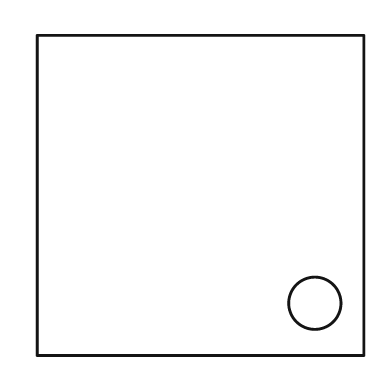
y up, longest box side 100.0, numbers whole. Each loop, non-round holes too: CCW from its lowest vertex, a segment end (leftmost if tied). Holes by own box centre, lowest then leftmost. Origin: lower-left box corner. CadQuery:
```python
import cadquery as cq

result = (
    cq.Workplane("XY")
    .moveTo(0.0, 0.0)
    .lineTo(100.0, 0.0)
    .lineTo(100.0, 98.0)
    .lineTo(0.0, 98.0)
    .close()
    .moveTo(85.0, 16.0)
    .circle(8.0)
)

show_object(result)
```